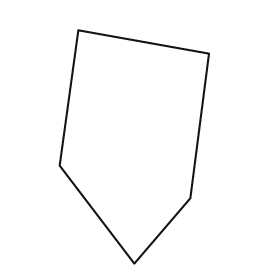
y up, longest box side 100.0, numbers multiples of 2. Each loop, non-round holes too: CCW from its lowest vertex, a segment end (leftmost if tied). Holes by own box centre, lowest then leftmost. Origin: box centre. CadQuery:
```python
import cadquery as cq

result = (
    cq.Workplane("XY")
    .moveTo(0.0, -50.0)
    .lineTo(24.0, -22.0)
    .lineTo(32.0, 40.0)
    .lineTo(-24.0, 50.0)
    .lineTo(-32.0, -8.0)
    .close()
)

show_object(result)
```